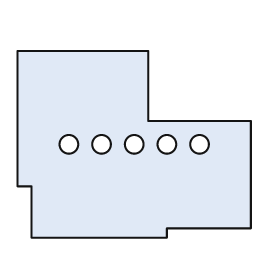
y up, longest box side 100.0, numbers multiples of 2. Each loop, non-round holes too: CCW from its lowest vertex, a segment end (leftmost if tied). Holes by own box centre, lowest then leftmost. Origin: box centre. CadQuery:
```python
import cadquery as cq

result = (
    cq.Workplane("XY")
    .moveTo(-44.0, -40.0)
    .lineTo(14.0, -40.0)
    .lineTo(14.0, -36.0)
    .lineTo(50.0, -36.0)
    .lineTo(50.0, 10.0)
    .lineTo(6.0, 10.0)
    .lineTo(6.0, 40.0)
    .lineTo(-50.0, 40.0)
    .lineTo(-50.0, -18.0)
    .lineTo(-44.0, -18.0)
    .close()
    .moveTo(-28.0, 0.0)
    .circle(4.0)
    .moveTo(-14.0, 0.0)
    .circle(4.0)
    .moveTo(0.0, 0.0)
    .circle(4.0)
    .moveTo(14.0, 0.0)
    .circle(4.0)
    .moveTo(28.0, 0.0)
    .circle(4.0)
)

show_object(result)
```